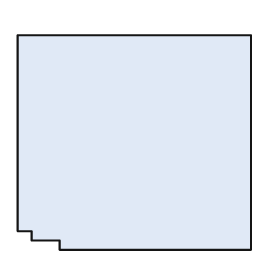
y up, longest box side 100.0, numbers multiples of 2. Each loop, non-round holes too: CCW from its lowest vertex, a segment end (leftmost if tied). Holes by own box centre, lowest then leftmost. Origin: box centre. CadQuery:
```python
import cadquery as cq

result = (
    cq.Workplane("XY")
    .moveTo(-32.0, -46.0)
    .lineTo(50.0, -46.0)
    .lineTo(50.0, 46.0)
    .lineTo(-50.0, 46.0)
    .lineTo(-50.0, -38.0)
    .lineTo(-44.0, -38.0)
    .lineTo(-44.0, -42.0)
    .lineTo(-32.0, -42.0)
    .close()
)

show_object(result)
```